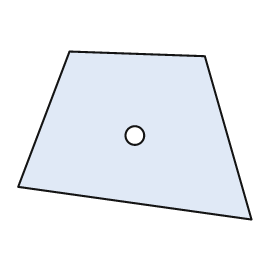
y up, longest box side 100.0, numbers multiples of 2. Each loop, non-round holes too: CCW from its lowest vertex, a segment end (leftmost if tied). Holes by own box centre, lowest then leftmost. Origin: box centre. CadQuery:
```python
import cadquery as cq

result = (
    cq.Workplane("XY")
    .moveTo(50.0, -36.0)
    .lineTo(30.0, 34.0)
    .lineTo(-28.0, 36.0)
    .lineTo(-50.0, -22.0)
    .close()
    .moveTo(0.0, 0.0)
    .circle(4.0)
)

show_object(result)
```